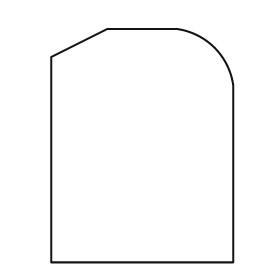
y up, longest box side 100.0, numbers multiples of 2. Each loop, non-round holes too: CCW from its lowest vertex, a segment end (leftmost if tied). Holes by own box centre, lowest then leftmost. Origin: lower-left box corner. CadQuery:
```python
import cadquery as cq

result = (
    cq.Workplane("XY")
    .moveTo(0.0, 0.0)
    .lineTo(78.0, 0.0)
    .lineTo(78.0, 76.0)
    .threePointArc((70.0, 92.0), (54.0, 100.0))
    .lineTo(24.0, 100.0)
    .lineTo(0.0, 88.0)
    .close()
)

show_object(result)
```